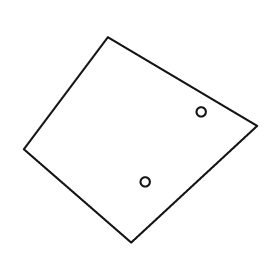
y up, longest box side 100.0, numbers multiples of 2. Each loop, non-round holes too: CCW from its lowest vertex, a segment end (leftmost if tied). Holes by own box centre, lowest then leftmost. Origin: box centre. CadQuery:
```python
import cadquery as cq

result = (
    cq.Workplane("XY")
    .moveTo(-4.0, -44.0)
    .lineTo(50.0, 6.0)
    .lineTo(-14.0, 44.0)
    .lineTo(-50.0, -4.0)
    .close()
    .moveTo(2.0, -18.0)
    .circle(2.0)
    .moveTo(26.0, 12.0)
    .circle(2.0)
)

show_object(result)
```